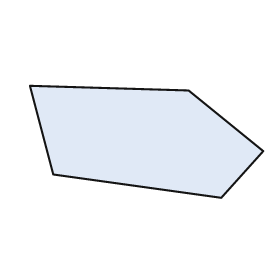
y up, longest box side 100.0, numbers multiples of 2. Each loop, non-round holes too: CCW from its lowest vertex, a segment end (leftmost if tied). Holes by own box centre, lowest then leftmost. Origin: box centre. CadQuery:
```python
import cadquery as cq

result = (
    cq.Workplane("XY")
    .moveTo(32.0, -24.0)
    .lineTo(50.0, -4.0)
    .lineTo(18.0, 22.0)
    .lineTo(-50.0, 24.0)
    .lineTo(-40.0, -14.0)
    .close()
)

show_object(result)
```